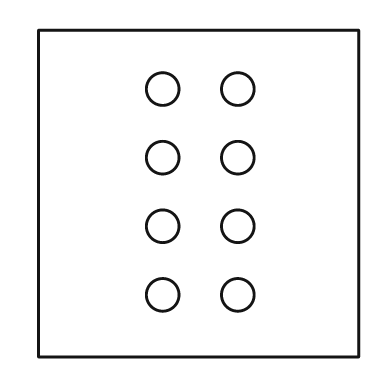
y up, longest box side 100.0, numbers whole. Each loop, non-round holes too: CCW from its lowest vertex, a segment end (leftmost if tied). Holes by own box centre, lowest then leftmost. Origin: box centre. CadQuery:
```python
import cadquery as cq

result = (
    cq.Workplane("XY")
    .moveTo(-49.0, -50.0)
    .lineTo(49.0, -50.0)
    .lineTo(49.0, 50.0)
    .lineTo(-49.0, 50.0)
    .close()
    .moveTo(-11.0, -31.0)
    .circle(5.0)
    .moveTo(12.0, -31.0)
    .circle(5.0)
    .moveTo(-11.0, -10.0)
    .circle(5.0)
    .moveTo(12.0, -10.0)
    .circle(5.0)
    .moveTo(-11.0, 11.0)
    .circle(5.0)
    .moveTo(12.0, 11.0)
    .circle(5.0)
    .moveTo(-11.0, 32.0)
    .circle(5.0)
    .moveTo(12.0, 32.0)
    .circle(5.0)
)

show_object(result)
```